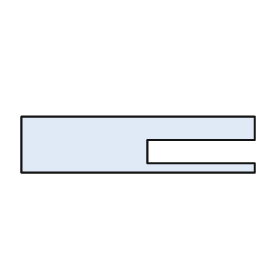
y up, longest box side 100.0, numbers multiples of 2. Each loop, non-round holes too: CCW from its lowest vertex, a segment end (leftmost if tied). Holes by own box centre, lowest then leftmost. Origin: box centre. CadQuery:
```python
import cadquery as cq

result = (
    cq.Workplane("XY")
    .moveTo(-50.0, -12.0)
    .lineTo(50.0, -12.0)
    .lineTo(50.0, -8.0)
    .lineTo(4.0, -8.0)
    .lineTo(4.0, 2.0)
    .lineTo(50.0, 2.0)
    .lineTo(50.0, 12.0)
    .lineTo(-50.0, 12.0)
    .close()
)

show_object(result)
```